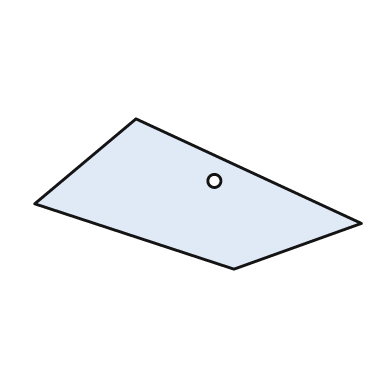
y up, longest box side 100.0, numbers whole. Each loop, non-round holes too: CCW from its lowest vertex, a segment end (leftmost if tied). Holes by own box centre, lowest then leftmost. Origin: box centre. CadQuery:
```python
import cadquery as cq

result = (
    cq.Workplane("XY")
    .moveTo(11.0, -23.0)
    .lineTo(50.0, -9.0)
    .lineTo(-19.0, 23.0)
    .lineTo(-50.0, -3.0)
    .close()
    .moveTo(5.0, 4.0)
    .circle(2.0)
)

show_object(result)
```